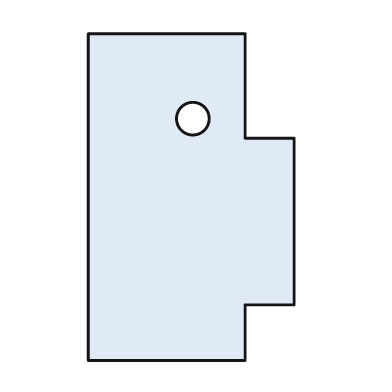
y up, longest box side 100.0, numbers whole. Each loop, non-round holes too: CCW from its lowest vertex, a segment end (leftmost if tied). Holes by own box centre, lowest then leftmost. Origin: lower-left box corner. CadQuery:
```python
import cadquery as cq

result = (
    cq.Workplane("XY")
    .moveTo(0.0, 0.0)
    .lineTo(48.0, 0.0)
    .lineTo(48.0, 17.0)
    .lineTo(63.0, 17.0)
    .lineTo(63.0, 68.0)
    .lineTo(48.0, 68.0)
    .lineTo(48.0, 100.0)
    .lineTo(0.0, 100.0)
    .close()
    .moveTo(32.0, 74.0)
    .circle(5.0)
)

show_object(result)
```